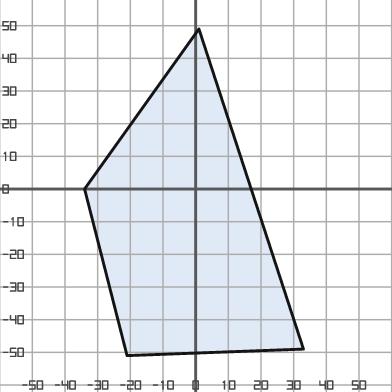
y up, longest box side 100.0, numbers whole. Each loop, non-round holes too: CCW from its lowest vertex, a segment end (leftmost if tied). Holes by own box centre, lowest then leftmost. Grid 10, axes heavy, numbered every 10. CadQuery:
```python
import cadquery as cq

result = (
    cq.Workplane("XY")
    .moveTo(-21.0, -51.0)
    .lineTo(33.0, -49.0)
    .lineTo(1.0, 49.0)
    .lineTo(-34.0, 0.0)
    .close()
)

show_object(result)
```